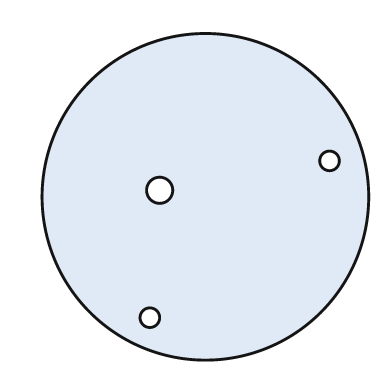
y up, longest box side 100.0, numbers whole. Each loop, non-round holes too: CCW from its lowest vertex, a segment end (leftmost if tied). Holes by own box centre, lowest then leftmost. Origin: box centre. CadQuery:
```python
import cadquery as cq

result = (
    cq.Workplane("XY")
    .moveTo(0.0, 0.0)
    .circle(50.0)
    .moveTo(-17.0, -37.0)
    .circle(3.0)
    .moveTo(-14.0, 2.0)
    .circle(4.0)
    .moveTo(38.0, 11.0)
    .circle(3.0)
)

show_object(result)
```